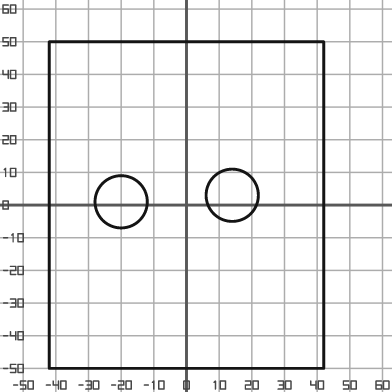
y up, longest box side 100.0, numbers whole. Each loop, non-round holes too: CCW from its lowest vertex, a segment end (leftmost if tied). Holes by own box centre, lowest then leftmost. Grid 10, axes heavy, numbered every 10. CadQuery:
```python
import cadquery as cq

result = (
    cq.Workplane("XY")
    .moveTo(-42.0, -50.0)
    .lineTo(42.0, -50.0)
    .lineTo(42.0, 50.0)
    .lineTo(-42.0, 50.0)
    .close()
    .moveTo(-20.0, 1.0)
    .circle(8.0)
    .moveTo(14.0, 3.0)
    .circle(8.0)
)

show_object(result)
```